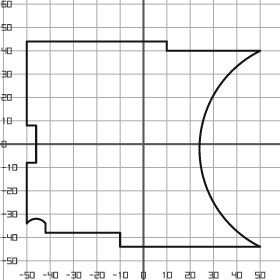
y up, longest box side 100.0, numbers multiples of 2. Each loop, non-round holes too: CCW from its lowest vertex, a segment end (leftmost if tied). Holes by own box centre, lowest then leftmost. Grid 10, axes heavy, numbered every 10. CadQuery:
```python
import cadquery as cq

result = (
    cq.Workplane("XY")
    .moveTo(-10.0, -44.0)
    .lineTo(50.0, -44.0)
    .threePointArc((24.0, -2.0), (50.0, 40.0))
    .lineTo(10.0, 40.0)
    .lineTo(10.0, 44.0)
    .lineTo(-50.0, 44.0)
    .lineTo(-50.0, 8.0)
    .lineTo(-46.0, 8.0)
    .lineTo(-46.0, -8.0)
    .lineTo(-50.0, -8.0)
    .lineTo(-50.0, -34.0)
    .threePointArc((-46.0, -32.0), (-42.0, -34.0))
    .lineTo(-42.0, -38.0)
    .lineTo(-10.0, -38.0)
    .close()
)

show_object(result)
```